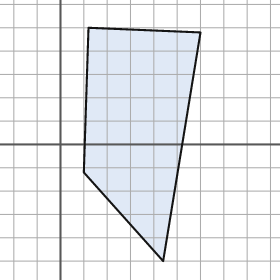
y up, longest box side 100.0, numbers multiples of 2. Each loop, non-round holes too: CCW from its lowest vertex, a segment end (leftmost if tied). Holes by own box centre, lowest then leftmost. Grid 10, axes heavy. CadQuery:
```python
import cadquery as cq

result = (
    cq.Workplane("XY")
    .moveTo(44.0, -50.0)
    .lineTo(60.0, 48.0)
    .lineTo(12.0, 50.0)
    .lineTo(10.0, -12.0)
    .close()
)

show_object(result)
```